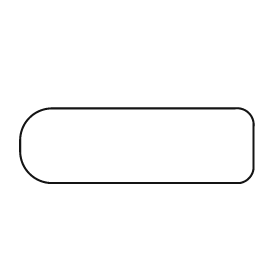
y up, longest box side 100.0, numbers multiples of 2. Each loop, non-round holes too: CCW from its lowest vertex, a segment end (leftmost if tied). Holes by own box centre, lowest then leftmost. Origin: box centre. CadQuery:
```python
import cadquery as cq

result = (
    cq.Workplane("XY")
    .moveTo(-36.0, -16.0)
    .lineTo(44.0, -16.0)
    .threePointArc((48.0, -14.0), (50.0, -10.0))
    .lineTo(50.0, 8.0)
    .threePointArc((48.0, 14.0), (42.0, 16.0))
    .lineTo(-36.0, 16.0)
    .threePointArc((-46.0, 12.0), (-50.0, 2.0))
    .lineTo(-50.0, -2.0)
    .threePointArc((-46.0, -12.0), (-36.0, -16.0))
    .close()
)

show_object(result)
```